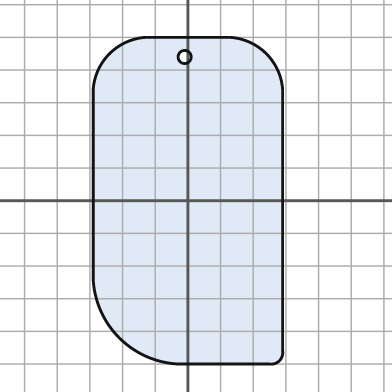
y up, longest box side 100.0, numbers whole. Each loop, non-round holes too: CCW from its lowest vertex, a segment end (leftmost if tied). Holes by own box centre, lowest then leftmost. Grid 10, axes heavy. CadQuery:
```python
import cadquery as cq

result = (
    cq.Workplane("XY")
    .moveTo(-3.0, -50.0)
    .lineTo(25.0, -50.0)
    .threePointArc((28.0, -49.0), (29.0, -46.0))
    .lineTo(29.0, 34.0)
    .threePointArc((24.0, 45.0), (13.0, 50.0))
    .lineTo(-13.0, 50.0)
    .threePointArc((-24.0, 45.0), (-29.0, 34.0))
    .lineTo(-29.0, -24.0)
    .threePointArc((-21.0, -42.0), (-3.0, -50.0))
    .close()
    .moveTo(-1.0, 44.0)
    .circle(2.0)
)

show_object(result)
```